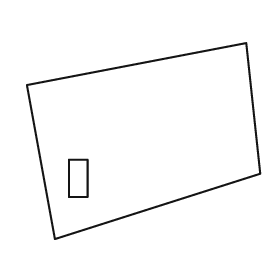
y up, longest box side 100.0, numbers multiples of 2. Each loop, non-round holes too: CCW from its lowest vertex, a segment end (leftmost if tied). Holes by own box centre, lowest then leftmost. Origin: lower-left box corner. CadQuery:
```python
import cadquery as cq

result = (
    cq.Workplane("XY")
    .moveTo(12.0, 0.0)
    .lineTo(100.0, 28.0)
    .lineTo(94.0, 84.0)
    .lineTo(0.0, 66.0)
    .close()
    .moveTo(18.0, 18.0)
    .lineTo(26.0, 18.0)
    .lineTo(26.0, 34.0)
    .lineTo(18.0, 34.0)
    .close()
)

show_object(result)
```